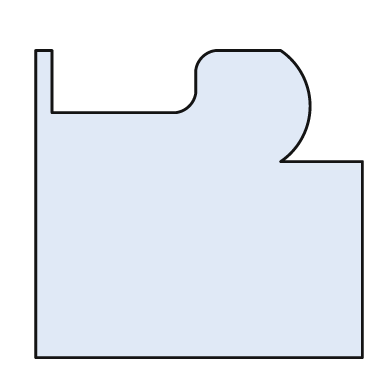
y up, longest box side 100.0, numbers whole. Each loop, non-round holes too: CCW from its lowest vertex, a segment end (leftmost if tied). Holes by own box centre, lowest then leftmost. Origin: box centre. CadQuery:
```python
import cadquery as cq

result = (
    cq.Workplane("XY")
    .moveTo(-50.0, -47.0)
    .lineTo(50.0, -47.0)
    .lineTo(50.0, 13.0)
    .lineTo(25.0, 13.0)
    .threePointArc((34.0, 30.0), (25.0, 47.0))
    .lineTo(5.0, 47.0)
    .threePointArc((1.0, 45.0), (-1.0, 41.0))
    .lineTo(-1.0, 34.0)
    .threePointArc((-3.0, 30.0), (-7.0, 28.0))
    .lineTo(-45.0, 28.0)
    .lineTo(-45.0, 47.0)
    .lineTo(-50.0, 47.0)
    .close()
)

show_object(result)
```